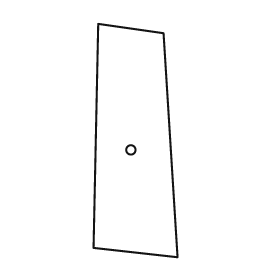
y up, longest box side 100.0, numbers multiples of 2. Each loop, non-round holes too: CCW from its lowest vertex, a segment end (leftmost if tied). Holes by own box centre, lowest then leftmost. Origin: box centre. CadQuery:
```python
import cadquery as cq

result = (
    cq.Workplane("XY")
    .moveTo(18.0, -50.0)
    .lineTo(12.0, 46.0)
    .lineTo(-16.0, 50.0)
    .lineTo(-18.0, -46.0)
    .close()
    .moveTo(-2.0, -4.0)
    .circle(2.0)
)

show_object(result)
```